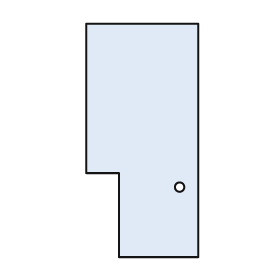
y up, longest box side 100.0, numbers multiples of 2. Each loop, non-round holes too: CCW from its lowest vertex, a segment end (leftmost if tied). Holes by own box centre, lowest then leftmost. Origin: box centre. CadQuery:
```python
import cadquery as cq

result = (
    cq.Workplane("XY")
    .moveTo(-10.0, -50.0)
    .lineTo(24.0, -50.0)
    .lineTo(24.0, 50.0)
    .lineTo(-24.0, 50.0)
    .lineTo(-24.0, -14.0)
    .lineTo(-10.0, -14.0)
    .close()
    .moveTo(16.0, -20.0)
    .circle(2.0)
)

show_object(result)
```